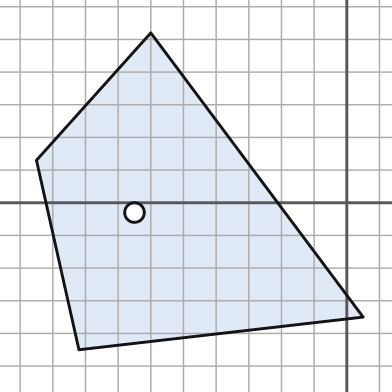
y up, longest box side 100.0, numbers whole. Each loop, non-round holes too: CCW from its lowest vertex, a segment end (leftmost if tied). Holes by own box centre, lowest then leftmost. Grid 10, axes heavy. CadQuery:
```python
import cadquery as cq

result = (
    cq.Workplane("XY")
    .moveTo(-82.0, -45.0)
    .lineTo(5.0, -35.0)
    .lineTo(-60.0, 52.0)
    .lineTo(-95.0, 13.0)
    .close()
    .moveTo(-65.0, -3.0)
    .circle(3.0)
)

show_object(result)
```